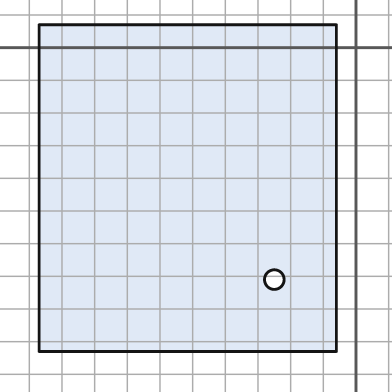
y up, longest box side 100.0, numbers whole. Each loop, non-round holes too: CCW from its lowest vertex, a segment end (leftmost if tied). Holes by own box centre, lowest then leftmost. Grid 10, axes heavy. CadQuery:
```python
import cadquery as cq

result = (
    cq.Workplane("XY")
    .moveTo(-97.0, -93.0)
    .lineTo(-6.0, -93.0)
    .lineTo(-6.0, 7.0)
    .lineTo(-97.0, 7.0)
    .close()
    .moveTo(-25.0, -71.0)
    .circle(3.0)
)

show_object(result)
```